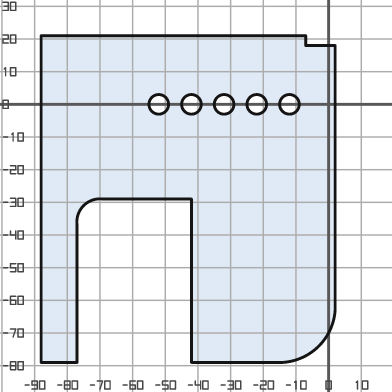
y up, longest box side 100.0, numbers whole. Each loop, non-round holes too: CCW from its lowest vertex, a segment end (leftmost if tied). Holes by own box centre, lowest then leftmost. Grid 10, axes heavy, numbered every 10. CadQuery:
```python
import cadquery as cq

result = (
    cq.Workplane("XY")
    .moveTo(-88.0, -79.0)
    .lineTo(-77.0, -79.0)
    .lineTo(-77.0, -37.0)
    .threePointArc((-75.0, -31.0), (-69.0, -29.0))
    .lineTo(-42.0, -29.0)
    .lineTo(-42.0, -79.0)
    .lineTo(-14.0, -79.0)
    .threePointArc((-3.0, -74.0), (2.0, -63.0))
    .lineTo(2.0, 18.0)
    .lineTo(-7.0, 18.0)
    .lineTo(-7.0, 21.0)
    .lineTo(-88.0, 21.0)
    .close()
    .moveTo(-52.0, 0.0)
    .circle(3.0)
    .moveTo(-42.0, 0.0)
    .circle(3.0)
    .moveTo(-32.0, 0.0)
    .circle(3.0)
    .moveTo(-22.0, 0.0)
    .circle(3.0)
    .moveTo(-12.0, 0.0)
    .circle(3.0)
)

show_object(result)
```